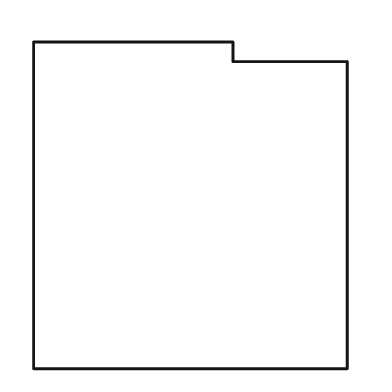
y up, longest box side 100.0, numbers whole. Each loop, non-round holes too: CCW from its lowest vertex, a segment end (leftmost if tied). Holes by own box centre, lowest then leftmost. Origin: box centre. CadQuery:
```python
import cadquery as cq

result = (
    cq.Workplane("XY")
    .moveTo(-48.0, -50.0)
    .lineTo(48.0, -50.0)
    .lineTo(48.0, 44.0)
    .lineTo(13.0, 44.0)
    .lineTo(13.0, 50.0)
    .lineTo(-48.0, 50.0)
    .close()
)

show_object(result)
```